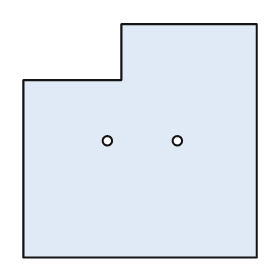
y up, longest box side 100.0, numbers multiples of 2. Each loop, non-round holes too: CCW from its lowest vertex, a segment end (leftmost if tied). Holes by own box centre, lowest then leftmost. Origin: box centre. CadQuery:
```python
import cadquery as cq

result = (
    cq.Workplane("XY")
    .moveTo(-50.0, -50.0)
    .lineTo(50.0, -50.0)
    .lineTo(50.0, 50.0)
    .lineTo(-8.0, 50.0)
    .lineTo(-8.0, 26.0)
    .lineTo(-50.0, 26.0)
    .close()
    .moveTo(-14.0, 0.0)
    .circle(2.0)
    .moveTo(16.0, 0.0)
    .circle(2.0)
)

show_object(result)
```